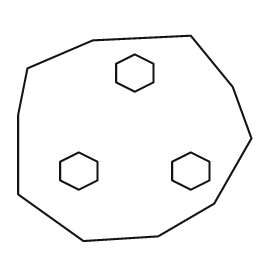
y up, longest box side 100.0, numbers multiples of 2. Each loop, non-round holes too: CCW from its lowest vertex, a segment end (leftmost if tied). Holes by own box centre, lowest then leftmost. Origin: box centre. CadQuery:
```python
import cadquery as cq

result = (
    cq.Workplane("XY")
    .moveTo(-22.0, -44.0)
    .lineTo(10.0, -42.0)
    .lineTo(34.0, -28.0)
    .lineTo(50.0, 0.0)
    .lineTo(42.0, 22.0)
    .lineTo(24.0, 44.0)
    .lineTo(-18.0, 42.0)
    .lineTo(-46.0, 30.0)
    .lineTo(-50.0, 10.0)
    .lineTo(-50.0, -24.0)
    .close()
    .moveTo(-24.0, -22.0)
    .lineTo(-16.0, -18.0)
    .lineTo(-16.0, -10.0)
    .lineTo(-24.0, -6.0)
    .lineTo(-32.0, -10.0)
    .lineTo(-32.0, -18.0)
    .close()
    .moveTo(24.0, -22.0)
    .lineTo(32.0, -18.0)
    .lineTo(32.0, -10.0)
    .lineTo(24.0, -6.0)
    .lineTo(16.0, -10.0)
    .lineTo(16.0, -18.0)
    .close()
    .moveTo(0.0, 20.0)
    .lineTo(8.0, 24.0)
    .lineTo(8.0, 32.0)
    .lineTo(0.0, 36.0)
    .lineTo(-8.0, 32.0)
    .lineTo(-8.0, 24.0)
    .close()
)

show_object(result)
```